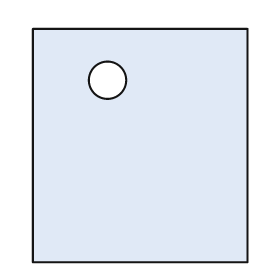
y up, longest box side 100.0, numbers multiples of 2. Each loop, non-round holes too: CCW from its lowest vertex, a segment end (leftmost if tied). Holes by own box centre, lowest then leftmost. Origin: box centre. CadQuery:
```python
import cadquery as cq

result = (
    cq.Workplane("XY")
    .moveTo(-46.0, -50.0)
    .lineTo(46.0, -50.0)
    .lineTo(46.0, 50.0)
    .lineTo(-46.0, 50.0)
    .close()
    .moveTo(-14.0, 28.0)
    .circle(8.0)
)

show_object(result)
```